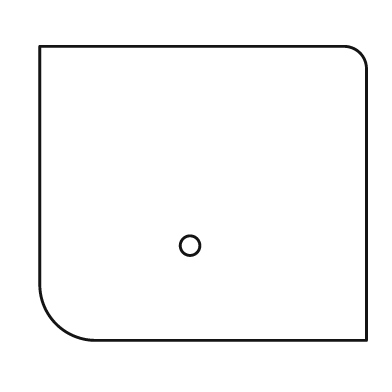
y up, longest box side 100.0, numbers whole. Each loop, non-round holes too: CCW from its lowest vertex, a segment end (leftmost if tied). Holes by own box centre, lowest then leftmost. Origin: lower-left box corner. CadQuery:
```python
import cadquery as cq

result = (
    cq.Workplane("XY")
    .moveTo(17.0, 0.0)
    .lineTo(100.0, 0.0)
    .lineTo(100.0, 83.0)
    .threePointArc((98.0, 88.0), (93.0, 90.0))
    .lineTo(0.0, 90.0)
    .lineTo(0.0, 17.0)
    .threePointArc((5.0, 5.0), (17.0, 0.0))
    .close()
    .moveTo(46.0, 29.0)
    .circle(3.0)
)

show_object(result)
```